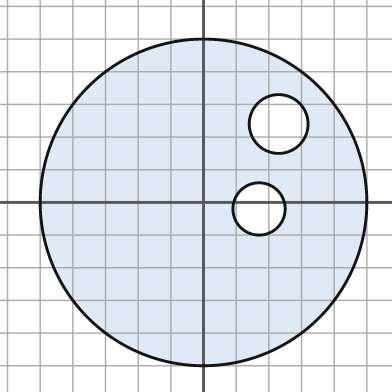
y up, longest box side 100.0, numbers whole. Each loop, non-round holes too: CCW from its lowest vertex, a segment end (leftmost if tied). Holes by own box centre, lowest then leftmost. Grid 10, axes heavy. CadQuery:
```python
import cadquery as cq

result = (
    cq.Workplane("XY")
    .moveTo(0.0, 0.0)
    .circle(50.0)
    .moveTo(17.0, -2.0)
    .circle(8.0)
    .moveTo(23.0, 24.0)
    .circle(9.0)
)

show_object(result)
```